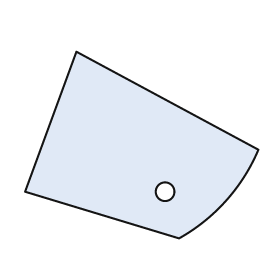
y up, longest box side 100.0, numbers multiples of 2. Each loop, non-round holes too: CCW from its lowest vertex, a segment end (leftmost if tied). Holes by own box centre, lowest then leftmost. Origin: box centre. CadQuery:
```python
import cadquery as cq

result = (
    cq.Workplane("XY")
    .moveTo(16.0, -40.0)
    .threePointArc((36.0, -24.0), (50.0, -2.0))
    .lineTo(-28.0, 40.0)
    .lineTo(-50.0, -20.0)
    .close()
    .moveTo(10.0, -20.0)
    .circle(4.0)
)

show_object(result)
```